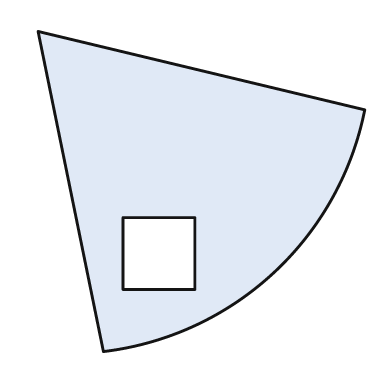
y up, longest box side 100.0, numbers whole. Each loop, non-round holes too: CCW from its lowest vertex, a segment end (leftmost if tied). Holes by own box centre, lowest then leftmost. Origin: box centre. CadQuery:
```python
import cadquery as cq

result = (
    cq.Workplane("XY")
    .moveTo(-30.0, -49.0)
    .threePointArc((22.0, -25.0), (50.0, 25.0))
    .lineTo(-50.0, 49.0)
    .close()
    .moveTo(-24.0, -30.0)
    .lineTo(-2.0, -30.0)
    .lineTo(-2.0, -8.0)
    .lineTo(-24.0, -8.0)
    .close()
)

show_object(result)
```